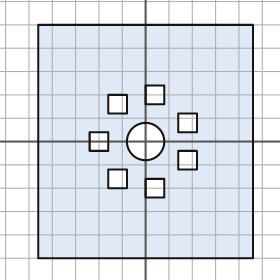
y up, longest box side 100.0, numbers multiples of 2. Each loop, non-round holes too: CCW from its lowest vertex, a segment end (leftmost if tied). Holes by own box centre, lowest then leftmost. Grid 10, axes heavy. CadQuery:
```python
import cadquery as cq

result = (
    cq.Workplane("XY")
    .moveTo(-46.0, -50.0)
    .lineTo(46.0, -50.0)
    .lineTo(46.0, 50.0)
    .lineTo(-46.0, 50.0)
    .close()
    .moveTo(0.0, -24.0)
    .lineTo(8.0, -24.0)
    .lineTo(8.0, -16.0)
    .lineTo(0.0, -16.0)
    .close()
    .moveTo(-16.0, -20.0)
    .lineTo(-8.0, -20.0)
    .lineTo(-8.0, -12.0)
    .lineTo(-16.0, -12.0)
    .close()
    .moveTo(14.0, -12.0)
    .lineTo(22.0, -12.0)
    .lineTo(22.0, -4.0)
    .lineTo(14.0, -4.0)
    .close()
    .moveTo(-24.0, -4.0)
    .lineTo(-16.0, -4.0)
    .lineTo(-16.0, 4.0)
    .lineTo(-24.0, 4.0)
    .close()
    .moveTo(0.0, 0.0)
    .circle(8.0)
    .moveTo(14.0, 4.0)
    .lineTo(22.0, 4.0)
    .lineTo(22.0, 12.0)
    .lineTo(14.0, 12.0)
    .close()
    .moveTo(-16.0, 12.0)
    .lineTo(-8.0, 12.0)
    .lineTo(-8.0, 20.0)
    .lineTo(-16.0, 20.0)
    .close()
    .moveTo(0.0, 16.0)
    .lineTo(8.0, 16.0)
    .lineTo(8.0, 24.0)
    .lineTo(0.0, 24.0)
    .close()
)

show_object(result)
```